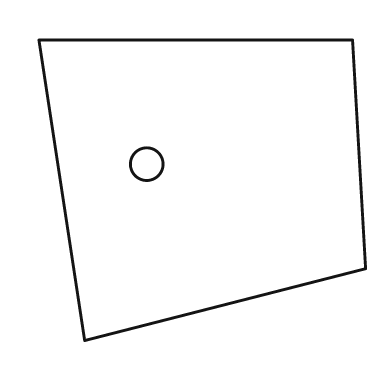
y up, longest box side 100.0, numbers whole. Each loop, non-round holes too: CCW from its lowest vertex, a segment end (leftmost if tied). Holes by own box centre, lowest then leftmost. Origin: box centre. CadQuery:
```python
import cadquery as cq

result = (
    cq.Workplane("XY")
    .moveTo(-36.0, -46.0)
    .lineTo(50.0, -24.0)
    .lineTo(46.0, 46.0)
    .lineTo(-50.0, 46.0)
    .close()
    .moveTo(-17.0, 8.0)
    .circle(5.0)
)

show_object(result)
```